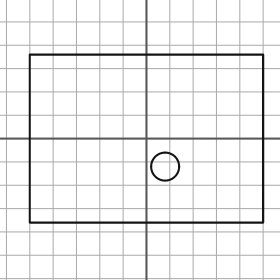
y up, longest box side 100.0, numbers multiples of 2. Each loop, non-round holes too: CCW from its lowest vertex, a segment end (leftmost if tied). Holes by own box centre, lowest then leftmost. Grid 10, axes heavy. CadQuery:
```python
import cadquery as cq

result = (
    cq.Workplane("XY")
    .moveTo(-50.0, -36.0)
    .lineTo(50.0, -36.0)
    .lineTo(50.0, 36.0)
    .lineTo(-50.0, 36.0)
    .close()
    .moveTo(8.0, -12.0)
    .circle(6.0)
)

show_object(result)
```